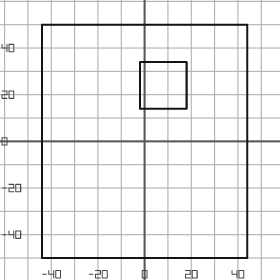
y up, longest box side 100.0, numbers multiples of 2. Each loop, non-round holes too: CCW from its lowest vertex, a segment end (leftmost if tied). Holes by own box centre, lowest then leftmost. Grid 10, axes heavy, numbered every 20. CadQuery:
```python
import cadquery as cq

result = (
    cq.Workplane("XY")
    .moveTo(-44.0, -50.0)
    .lineTo(44.0, -50.0)
    .lineTo(44.0, 50.0)
    .lineTo(-44.0, 50.0)
    .close()
    .moveTo(-2.0, 14.0)
    .lineTo(18.0, 14.0)
    .lineTo(18.0, 34.0)
    .lineTo(-2.0, 34.0)
    .close()
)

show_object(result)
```